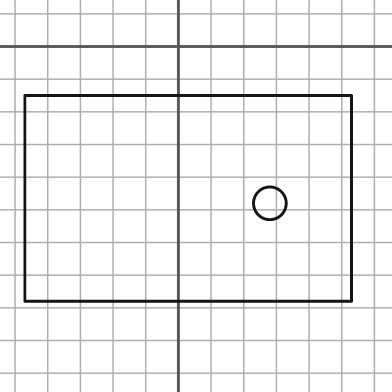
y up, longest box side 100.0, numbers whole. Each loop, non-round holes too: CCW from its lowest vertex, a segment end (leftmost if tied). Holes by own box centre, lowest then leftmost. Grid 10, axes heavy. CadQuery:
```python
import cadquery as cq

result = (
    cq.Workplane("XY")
    .moveTo(-47.0, -78.0)
    .lineTo(53.0, -78.0)
    .lineTo(53.0, -15.0)
    .lineTo(-47.0, -15.0)
    .close()
    .moveTo(28.0, -48.0)
    .circle(5.0)
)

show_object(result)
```